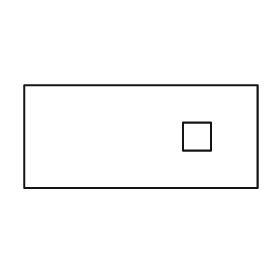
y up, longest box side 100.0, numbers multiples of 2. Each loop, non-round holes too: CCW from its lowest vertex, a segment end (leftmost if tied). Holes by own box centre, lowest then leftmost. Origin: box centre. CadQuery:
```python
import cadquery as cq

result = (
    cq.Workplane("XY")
    .moveTo(-50.0, -22.0)
    .lineTo(50.0, -22.0)
    .lineTo(50.0, 22.0)
    .lineTo(-50.0, 22.0)
    .close()
    .moveTo(18.0, -6.0)
    .lineTo(30.0, -6.0)
    .lineTo(30.0, 6.0)
    .lineTo(18.0, 6.0)
    .close()
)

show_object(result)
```